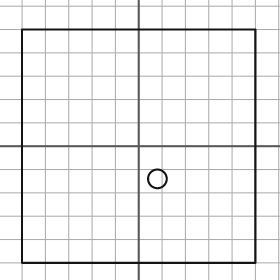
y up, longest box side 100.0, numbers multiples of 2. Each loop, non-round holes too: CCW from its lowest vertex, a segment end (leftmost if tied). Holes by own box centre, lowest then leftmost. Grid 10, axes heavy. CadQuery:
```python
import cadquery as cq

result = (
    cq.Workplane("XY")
    .moveTo(-50.0, -50.0)
    .lineTo(50.0, -50.0)
    .lineTo(50.0, 50.0)
    .lineTo(-50.0, 50.0)
    .close()
    .moveTo(8.0, -14.0)
    .circle(4.0)
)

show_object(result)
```